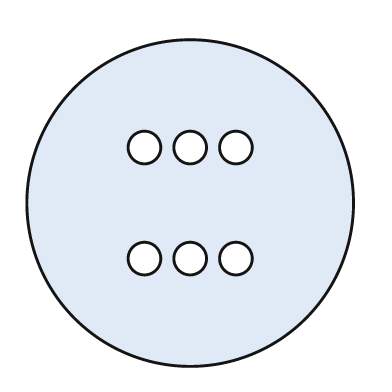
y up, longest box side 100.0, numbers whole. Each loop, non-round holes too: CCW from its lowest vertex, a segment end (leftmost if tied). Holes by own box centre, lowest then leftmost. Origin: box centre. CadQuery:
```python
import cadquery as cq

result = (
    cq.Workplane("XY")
    .moveTo(0.0, 0.0)
    .circle(50.0)
    .moveTo(-14.0, -17.0)
    .circle(5.0)
    .moveTo(0.0, -17.0)
    .circle(5.0)
    .moveTo(14.0, -17.0)
    .circle(5.0)
    .moveTo(-14.0, 17.0)
    .circle(5.0)
    .moveTo(0.0, 17.0)
    .circle(5.0)
    .moveTo(14.0, 17.0)
    .circle(5.0)
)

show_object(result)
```